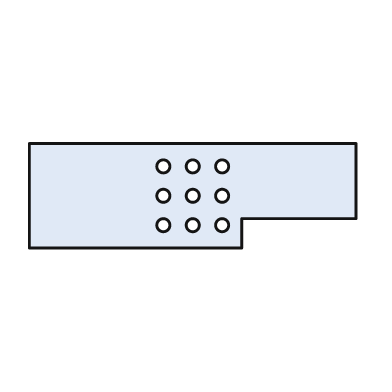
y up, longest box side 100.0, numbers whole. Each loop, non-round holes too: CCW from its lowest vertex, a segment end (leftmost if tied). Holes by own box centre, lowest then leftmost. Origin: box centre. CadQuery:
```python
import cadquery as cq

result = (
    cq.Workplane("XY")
    .moveTo(-50.0, -16.0)
    .lineTo(15.0, -16.0)
    .lineTo(15.0, -7.0)
    .lineTo(50.0, -7.0)
    .lineTo(50.0, 16.0)
    .lineTo(-50.0, 16.0)
    .close()
    .moveTo(-9.0, -9.0)
    .circle(2.0)
    .moveTo(0.0, -9.0)
    .circle(2.0)
    .moveTo(9.0, -9.0)
    .circle(2.0)
    .moveTo(-9.0, 0.0)
    .circle(2.0)
    .moveTo(0.0, 0.0)
    .circle(2.0)
    .moveTo(9.0, 0.0)
    .circle(2.0)
    .moveTo(-9.0, 9.0)
    .circle(2.0)
    .moveTo(0.0, 9.0)
    .circle(2.0)
    .moveTo(9.0, 9.0)
    .circle(2.0)
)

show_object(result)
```